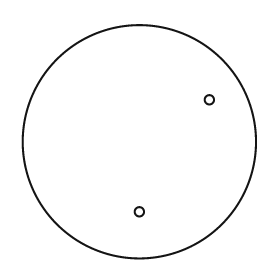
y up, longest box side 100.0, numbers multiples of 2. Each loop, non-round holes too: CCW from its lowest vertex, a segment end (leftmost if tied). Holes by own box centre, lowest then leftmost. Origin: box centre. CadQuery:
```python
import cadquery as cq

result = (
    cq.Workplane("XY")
    .moveTo(0.0, 0.0)
    .circle(50.0)
    .moveTo(0.0, -30.0)
    .circle(2.0)
    .moveTo(30.0, 18.0)
    .circle(2.0)
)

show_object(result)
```